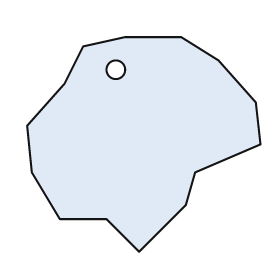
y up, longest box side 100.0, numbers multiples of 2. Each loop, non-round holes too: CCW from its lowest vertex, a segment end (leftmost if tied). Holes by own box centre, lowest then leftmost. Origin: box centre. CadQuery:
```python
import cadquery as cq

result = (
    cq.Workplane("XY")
    .moveTo(-2.0, -46.0)
    .lineTo(18.0, -26.0)
    .lineTo(22.0, -12.0)
    .lineTo(50.0, 0.0)
    .lineTo(48.0, 18.0)
    .lineTo(32.0, 36.0)
    .lineTo(16.0, 46.0)
    .lineTo(-8.0, 46.0)
    .lineTo(-26.0, 42.0)
    .lineTo(-34.0, 26.0)
    .lineTo(-50.0, 8.0)
    .lineTo(-48.0, -12.0)
    .lineTo(-36.0, -32.0)
    .lineTo(-16.0, -32.0)
    .close()
    .moveTo(-12.0, 32.0)
    .circle(4.0)
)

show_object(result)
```